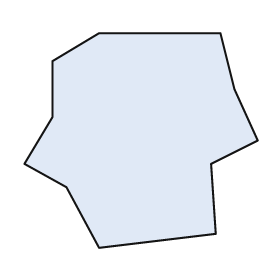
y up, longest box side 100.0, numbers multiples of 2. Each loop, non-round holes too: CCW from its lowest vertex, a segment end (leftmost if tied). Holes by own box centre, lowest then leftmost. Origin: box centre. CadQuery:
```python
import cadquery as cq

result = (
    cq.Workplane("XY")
    .moveTo(-18.0, -46.0)
    .lineTo(32.0, -40.0)
    .lineTo(30.0, -10.0)
    .lineTo(50.0, 0.0)
    .lineTo(40.0, 22.0)
    .lineTo(34.0, 46.0)
    .lineTo(-18.0, 46.0)
    .lineTo(-38.0, 34.0)
    .lineTo(-38.0, 10.0)
    .lineTo(-50.0, -10.0)
    .lineTo(-32.0, -20.0)
    .close()
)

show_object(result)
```